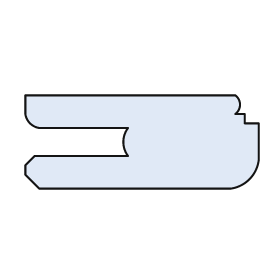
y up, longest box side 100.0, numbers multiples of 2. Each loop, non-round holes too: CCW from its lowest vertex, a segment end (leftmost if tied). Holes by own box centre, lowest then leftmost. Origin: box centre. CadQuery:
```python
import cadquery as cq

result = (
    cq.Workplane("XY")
    .moveTo(-44.0, -20.0)
    .lineTo(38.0, -20.0)
    .threePointArc((46.0, -16.0), (50.0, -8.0))
    .lineTo(50.0, 8.0)
    .lineTo(44.0, 8.0)
    .lineTo(44.0, 12.0)
    .lineTo(40.0, 12.0)
    .threePointArc((42.0, 16.0), (40.0, 20.0))
    .lineTo(-50.0, 20.0)
    .lineTo(-50.0, 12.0)
    .threePointArc((-48.0, 8.0), (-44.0, 6.0))
    .lineTo(-6.0, 6.0)
    .threePointArc((-8.0, 0.0), (-6.0, -6.0))
    .lineTo(-46.0, -6.0)
    .lineTo(-50.0, -10.0)
    .lineTo(-50.0, -14.0)
    .close()
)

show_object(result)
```